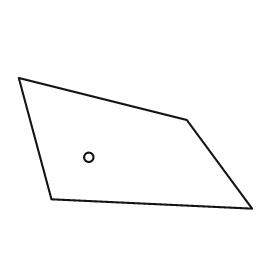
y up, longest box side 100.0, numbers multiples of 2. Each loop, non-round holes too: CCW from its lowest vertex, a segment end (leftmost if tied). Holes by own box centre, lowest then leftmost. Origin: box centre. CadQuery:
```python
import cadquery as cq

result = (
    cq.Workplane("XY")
    .moveTo(50.0, -28.0)
    .lineTo(22.0, 10.0)
    .lineTo(-50.0, 28.0)
    .lineTo(-36.0, -24.0)
    .close()
    .moveTo(-20.0, -6.0)
    .circle(2.0)
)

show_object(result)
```